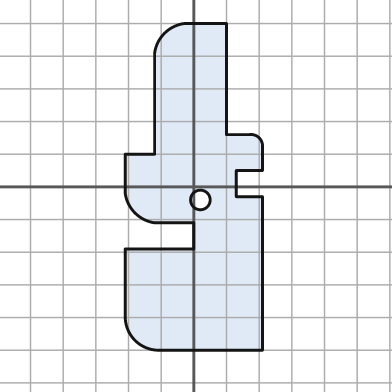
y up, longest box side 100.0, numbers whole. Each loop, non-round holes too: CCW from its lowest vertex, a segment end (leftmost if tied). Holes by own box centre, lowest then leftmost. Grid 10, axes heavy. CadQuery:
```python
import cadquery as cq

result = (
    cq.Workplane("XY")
    .moveTo(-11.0, -50.0)
    .lineTo(21.0, -50.0)
    .lineTo(21.0, -3.0)
    .lineTo(13.0, -3.0)
    .lineTo(13.0, 5.0)
    .lineTo(21.0, 5.0)
    .lineTo(21.0, 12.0)
    .threePointArc((20.0, 15.0), (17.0, 16.0))
    .lineTo(10.0, 16.0)
    .lineTo(10.0, 50.0)
    .lineTo(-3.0, 50.0)
    .threePointArc((-9.0, 47.0), (-12.0, 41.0))
    .lineTo(-12.0, 10.0)
    .lineTo(-21.0, 10.0)
    .lineTo(-21.0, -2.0)
    .threePointArc((-18.0, -8.0), (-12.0, -11.0))
    .lineTo(0.0, -11.0)
    .lineTo(0.0, -19.0)
    .lineTo(-21.0, -19.0)
    .lineTo(-21.0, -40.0)
    .threePointArc((-18.0, -47.0), (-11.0, -50.0))
    .close()
    .moveTo(2.0, -4.0)
    .circle(3.0)
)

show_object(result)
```